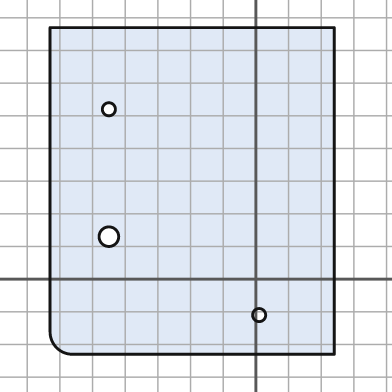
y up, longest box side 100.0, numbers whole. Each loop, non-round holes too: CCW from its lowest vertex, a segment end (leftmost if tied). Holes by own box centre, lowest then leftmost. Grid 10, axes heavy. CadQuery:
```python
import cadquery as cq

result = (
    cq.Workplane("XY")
    .moveTo(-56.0, -23.0)
    .lineTo(24.0, -23.0)
    .lineTo(24.0, 77.0)
    .lineTo(-63.0, 77.0)
    .lineTo(-63.0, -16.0)
    .threePointArc((-61.0, -21.0), (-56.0, -23.0))
    .close()
    .moveTo(1.0, -11.0)
    .circle(2.0)
    .moveTo(-45.0, 13.0)
    .circle(3.0)
    .moveTo(-45.0, 52.0)
    .circle(2.0)
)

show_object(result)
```